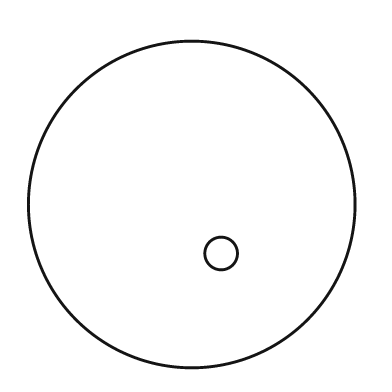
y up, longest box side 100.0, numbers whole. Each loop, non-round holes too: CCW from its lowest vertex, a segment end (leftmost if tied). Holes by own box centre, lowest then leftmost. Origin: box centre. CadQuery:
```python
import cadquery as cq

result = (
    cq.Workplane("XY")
    .moveTo(0.0, 0.0)
    .circle(50.0)
    .moveTo(9.0, -15.0)
    .circle(5.0)
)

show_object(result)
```